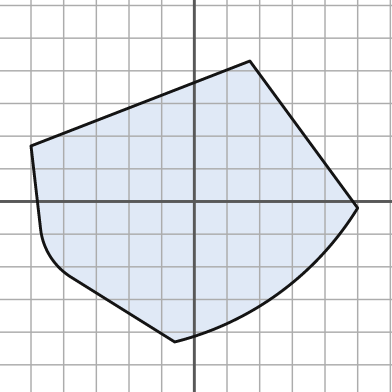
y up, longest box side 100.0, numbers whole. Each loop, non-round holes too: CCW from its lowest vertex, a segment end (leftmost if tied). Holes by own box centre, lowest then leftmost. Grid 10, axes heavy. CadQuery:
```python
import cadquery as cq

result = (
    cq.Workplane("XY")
    .moveTo(-6.0, -43.0)
    .threePointArc((26.0, -28.0), (50.0, -2.0))
    .lineTo(17.0, 43.0)
    .lineTo(-50.0, 17.0)
    .lineTo(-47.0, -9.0)
    .threePointArc((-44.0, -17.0), (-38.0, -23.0))
    .close()
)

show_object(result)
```